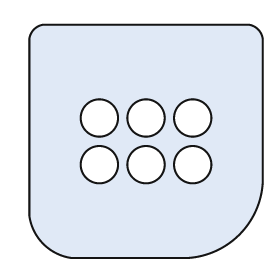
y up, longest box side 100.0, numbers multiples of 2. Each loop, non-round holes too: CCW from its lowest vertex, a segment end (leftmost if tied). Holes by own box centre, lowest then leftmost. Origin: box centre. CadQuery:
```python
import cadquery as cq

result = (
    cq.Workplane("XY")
    .moveTo(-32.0, -50.0)
    .lineTo(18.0, -50.0)
    .threePointArc((40.0, -40.0), (50.0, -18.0))
    .lineTo(50.0, 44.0)
    .threePointArc((48.0, 48.0), (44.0, 50.0))
    .lineTo(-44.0, 50.0)
    .threePointArc((-48.0, 48.0), (-50.0, 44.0))
    .lineTo(-50.0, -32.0)
    .threePointArc((-44.0, -44.0), (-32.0, -50.0))
    .close()
    .moveTo(-20.0, -10.0)
    .circle(8.0)
    .moveTo(0.0, -10.0)
    .circle(8.0)
    .moveTo(20.0, -10.0)
    .circle(8.0)
    .moveTo(-20.0, 10.0)
    .circle(8.0)
    .moveTo(0.0, 10.0)
    .circle(8.0)
    .moveTo(20.0, 10.0)
    .circle(8.0)
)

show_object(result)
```